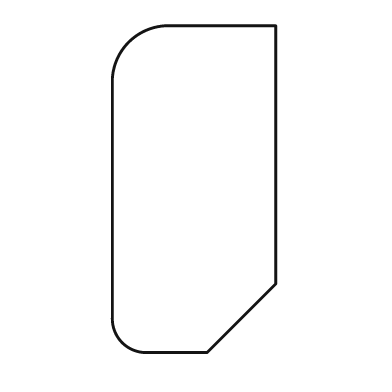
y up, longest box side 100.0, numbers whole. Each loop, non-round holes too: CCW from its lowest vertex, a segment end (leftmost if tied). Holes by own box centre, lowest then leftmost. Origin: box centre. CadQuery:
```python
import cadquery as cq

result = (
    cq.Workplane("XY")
    .moveTo(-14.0, -50.0)
    .lineTo(4.0, -50.0)
    .lineTo(25.0, -29.0)
    .lineTo(25.0, 50.0)
    .lineTo(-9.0, 50.0)
    .threePointArc((-20.0, 45.0), (-25.0, 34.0))
    .lineTo(-25.0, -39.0)
    .threePointArc((-22.0, -47.0), (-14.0, -50.0))
    .close()
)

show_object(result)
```